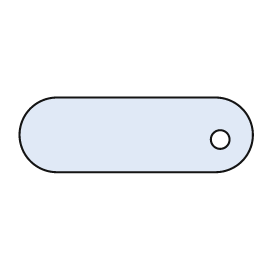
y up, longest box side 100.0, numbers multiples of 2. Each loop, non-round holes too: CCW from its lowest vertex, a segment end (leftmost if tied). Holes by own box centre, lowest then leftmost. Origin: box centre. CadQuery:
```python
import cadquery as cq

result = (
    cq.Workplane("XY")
    .moveTo(-34.0, -16.0)
    .lineTo(34.0, -16.0)
    .threePointArc((50.0, 0.0), (34.0, 16.0))
    .lineTo(-34.0, 16.0)
    .threePointArc((-50.0, 0.0), (-34.0, -16.0))
    .close()
    .moveTo(36.0, -2.0)
    .circle(4.0)
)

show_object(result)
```